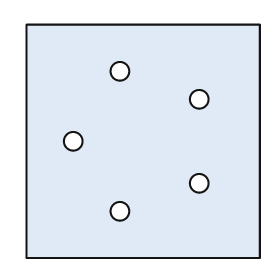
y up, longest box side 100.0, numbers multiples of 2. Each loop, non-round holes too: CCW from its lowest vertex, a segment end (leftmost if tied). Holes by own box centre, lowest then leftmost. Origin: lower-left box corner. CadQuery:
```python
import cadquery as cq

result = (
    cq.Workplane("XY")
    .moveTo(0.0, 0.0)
    .lineTo(100.0, 0.0)
    .lineTo(100.0, 100.0)
    .lineTo(0.0, 100.0)
    .close()
    .moveTo(40.0, 20.0)
    .circle(4.0)
    .moveTo(74.0, 32.0)
    .circle(4.0)
    .moveTo(20.0, 50.0)
    .circle(4.0)
    .moveTo(74.0, 68.0)
    .circle(4.0)
    .moveTo(40.0, 80.0)
    .circle(4.0)
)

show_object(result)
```